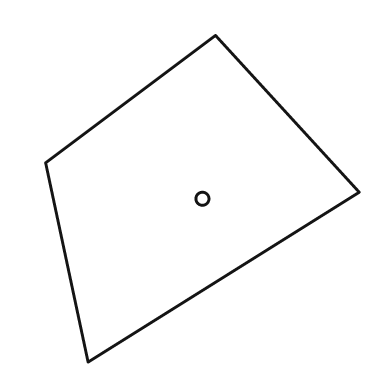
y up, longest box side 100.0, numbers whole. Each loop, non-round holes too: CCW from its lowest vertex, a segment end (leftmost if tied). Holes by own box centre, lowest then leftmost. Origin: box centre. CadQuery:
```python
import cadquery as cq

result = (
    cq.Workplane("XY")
    .moveTo(-35.0, -50.0)
    .lineTo(48.0, 2.0)
    .lineTo(4.0, 50.0)
    .lineTo(-48.0, 11.0)
    .close()
    .moveTo(0.0, 0.0)
    .circle(2.0)
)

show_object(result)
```